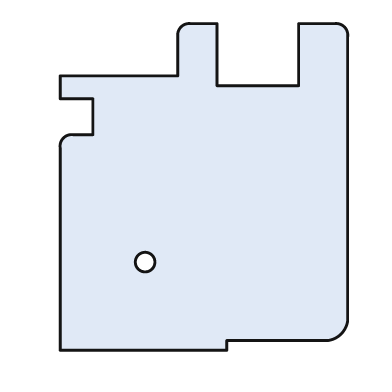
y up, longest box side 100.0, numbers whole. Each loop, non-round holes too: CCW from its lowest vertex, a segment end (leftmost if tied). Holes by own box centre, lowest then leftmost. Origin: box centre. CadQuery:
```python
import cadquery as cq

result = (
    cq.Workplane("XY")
    .moveTo(-44.0, -50.0)
    .lineTo(7.0, -50.0)
    .lineTo(7.0, -47.0)
    .lineTo(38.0, -47.0)
    .threePointArc((42.0, -45.0), (44.0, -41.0))
    .lineTo(44.0, 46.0)
    .threePointArc((43.0, 49.0), (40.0, 50.0))
    .lineTo(29.0, 50.0)
    .lineTo(29.0, 31.0)
    .lineTo(4.0, 31.0)
    .lineTo(4.0, 50.0)
    .lineTo(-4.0, 50.0)
    .threePointArc((-7.0, 49.0), (-8.0, 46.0))
    .lineTo(-8.0, 34.0)
    .lineTo(-44.0, 34.0)
    .lineTo(-44.0, 27.0)
    .lineTo(-34.0, 27.0)
    .lineTo(-34.0, 16.0)
    .lineTo(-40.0, 16.0)
    .threePointArc((-43.0, 15.0), (-44.0, 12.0))
    .close()
    .moveTo(-18.0, -23.0)
    .circle(3.0)
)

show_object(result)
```